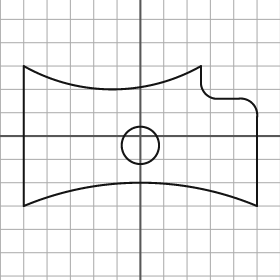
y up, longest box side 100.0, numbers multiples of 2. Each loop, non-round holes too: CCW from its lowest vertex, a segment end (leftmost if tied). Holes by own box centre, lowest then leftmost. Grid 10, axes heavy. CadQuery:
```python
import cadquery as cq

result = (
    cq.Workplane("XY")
    .moveTo(-50.0, -30.0)
    .threePointArc((0.0, -20.0), (50.0, -30.0))
    .lineTo(50.0, 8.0)
    .threePointArc((48.0, 14.0), (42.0, 16.0))
    .lineTo(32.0, 16.0)
    .threePointArc((28.0, 18.0), (26.0, 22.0))
    .lineTo(26.0, 30.0)
    .threePointArc((-12.0, 20.0), (-50.0, 30.0))
    .close()
    .moveTo(0.0, -4.0)
    .circle(8.0)
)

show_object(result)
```